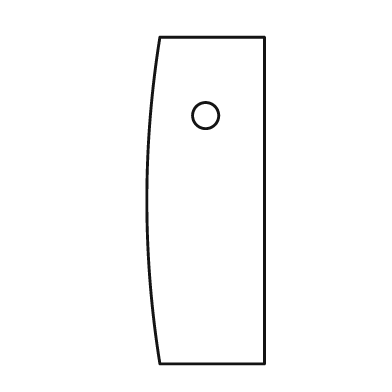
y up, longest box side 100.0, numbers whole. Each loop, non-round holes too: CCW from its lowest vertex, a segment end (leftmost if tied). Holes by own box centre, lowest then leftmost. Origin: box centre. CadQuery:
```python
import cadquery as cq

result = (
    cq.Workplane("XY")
    .moveTo(-14.0, -50.0)
    .lineTo(18.0, -50.0)
    .lineTo(18.0, 50.0)
    .lineTo(-14.0, 50.0)
    .threePointArc((-18.0, 0.0), (-14.0, -50.0))
    .close()
    .moveTo(0.0, 26.0)
    .circle(4.0)
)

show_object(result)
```